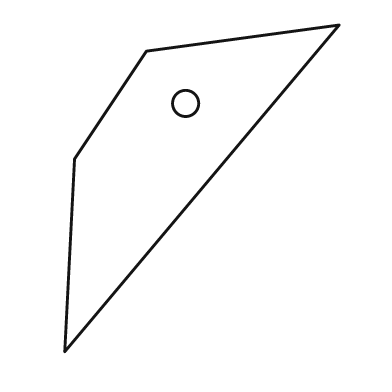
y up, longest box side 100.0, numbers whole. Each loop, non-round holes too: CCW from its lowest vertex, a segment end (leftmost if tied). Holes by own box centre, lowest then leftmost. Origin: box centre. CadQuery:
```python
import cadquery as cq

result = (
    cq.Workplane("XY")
    .moveTo(-42.0, -50.0)
    .lineTo(42.0, 50.0)
    .lineTo(-17.0, 42.0)
    .lineTo(-39.0, 9.0)
    .close()
    .moveTo(-5.0, 26.0)
    .circle(4.0)
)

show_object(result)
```